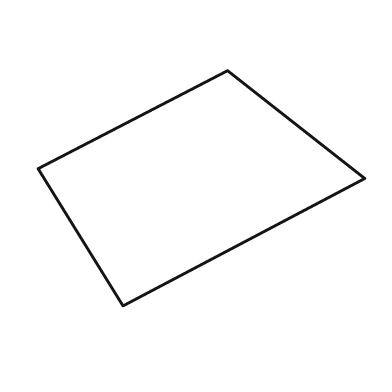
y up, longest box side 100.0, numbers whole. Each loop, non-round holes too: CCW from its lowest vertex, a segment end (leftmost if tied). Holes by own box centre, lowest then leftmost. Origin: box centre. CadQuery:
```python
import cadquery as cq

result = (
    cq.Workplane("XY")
    .moveTo(-24.0, -36.0)
    .lineTo(50.0, 3.0)
    .lineTo(8.0, 36.0)
    .lineTo(-50.0, 6.0)
    .close()
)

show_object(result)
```